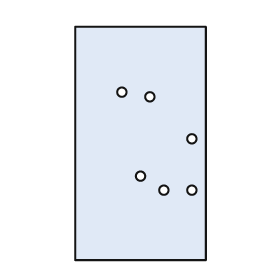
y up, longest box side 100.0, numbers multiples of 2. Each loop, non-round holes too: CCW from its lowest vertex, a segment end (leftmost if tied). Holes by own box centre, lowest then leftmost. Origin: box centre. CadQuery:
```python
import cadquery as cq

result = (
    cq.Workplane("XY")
    .moveTo(-28.0, -50.0)
    .lineTo(28.0, -50.0)
    .lineTo(28.0, 50.0)
    .lineTo(-28.0, 50.0)
    .close()
    .moveTo(10.0, -20.0)
    .circle(2.0)
    .moveTo(22.0, -20.0)
    .circle(2.0)
    .moveTo(0.0, -14.0)
    .circle(2.0)
    .moveTo(22.0, 2.0)
    .circle(2.0)
    .moveTo(4.0, 20.0)
    .circle(2.0)
    .moveTo(-8.0, 22.0)
    .circle(2.0)
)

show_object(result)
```